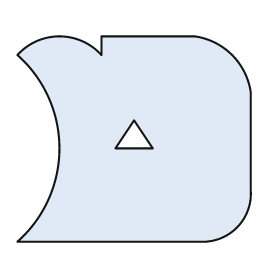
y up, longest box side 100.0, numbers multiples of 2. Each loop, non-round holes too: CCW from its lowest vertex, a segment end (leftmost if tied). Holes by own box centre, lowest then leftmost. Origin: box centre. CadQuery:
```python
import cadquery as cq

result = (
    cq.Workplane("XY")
    .moveTo(-50.0, -44.0)
    .lineTo(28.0, -44.0)
    .threePointArc((44.0, -38.0), (50.0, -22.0))
    .lineTo(50.0, 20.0)
    .threePointArc((42.0, 36.0), (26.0, 44.0))
    .lineTo(-14.0, 44.0)
    .lineTo(-14.0, 36.0)
    .threePointArc((-32.0, 44.0), (-50.0, 36.0))
    .threePointArc((-32.0, -4.0), (-50.0, -44.0))
    .close()
    .moveTo(-8.0, -4.0)
    .lineTo(8.0, -4.0)
    .lineTo(0.0, 8.0)
    .close()
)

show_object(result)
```